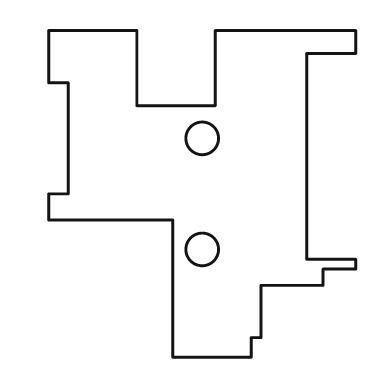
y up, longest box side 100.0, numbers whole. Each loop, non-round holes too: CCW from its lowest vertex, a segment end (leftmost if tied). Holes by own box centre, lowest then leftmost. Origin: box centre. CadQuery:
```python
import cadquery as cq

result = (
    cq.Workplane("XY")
    .moveTo(-9.0, -50.0)
    .lineTo(15.0, -50.0)
    .lineTo(15.0, -44.0)
    .lineTo(18.0, -44.0)
    .lineTo(18.0, -28.0)
    .lineTo(37.0, -28.0)
    .lineTo(37.0, -23.0)
    .lineTo(47.0, -23.0)
    .lineTo(47.0, -20.0)
    .lineTo(32.0, -20.0)
    .lineTo(32.0, 43.0)
    .lineTo(47.0, 43.0)
    .lineTo(47.0, 50.0)
    .lineTo(4.0, 50.0)
    .lineTo(4.0, 27.0)
    .lineTo(-20.0, 27.0)
    .lineTo(-20.0, 50.0)
    .lineTo(-47.0, 50.0)
    .lineTo(-47.0, 34.0)
    .lineTo(-41.0, 34.0)
    .lineTo(-41.0, 0.0)
    .lineTo(-47.0, 0.0)
    .lineTo(-47.0, -8.0)
    .lineTo(-9.0, -8.0)
    .close()
    .moveTo(0.0, -17.0)
    .circle(5.0)
    .moveTo(0.0, 17.0)
    .circle(5.0)
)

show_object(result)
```